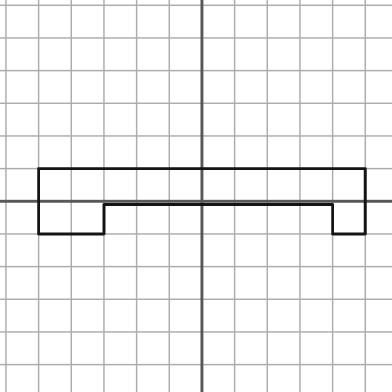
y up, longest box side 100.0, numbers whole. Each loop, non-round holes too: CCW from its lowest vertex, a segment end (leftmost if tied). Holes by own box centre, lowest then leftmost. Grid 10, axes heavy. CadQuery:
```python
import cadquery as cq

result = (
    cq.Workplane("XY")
    .moveTo(-50.0, -10.0)
    .lineTo(-30.0, -10.0)
    .lineTo(-30.0, -1.0)
    .lineTo(40.0, -1.0)
    .lineTo(40.0, -10.0)
    .lineTo(50.0, -10.0)
    .lineTo(50.0, 10.0)
    .lineTo(-50.0, 10.0)
    .close()
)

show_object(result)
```